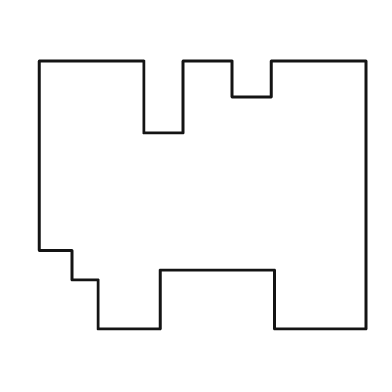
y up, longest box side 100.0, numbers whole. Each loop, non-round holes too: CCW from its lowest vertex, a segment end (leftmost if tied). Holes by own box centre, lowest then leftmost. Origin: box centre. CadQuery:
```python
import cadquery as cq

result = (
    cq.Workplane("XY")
    .moveTo(-32.0, -41.0)
    .lineTo(-13.0, -41.0)
    .lineTo(-13.0, -23.0)
    .lineTo(22.0, -23.0)
    .lineTo(22.0, -41.0)
    .lineTo(50.0, -41.0)
    .lineTo(50.0, 41.0)
    .lineTo(21.0, 41.0)
    .lineTo(21.0, 30.0)
    .lineTo(9.0, 30.0)
    .lineTo(9.0, 41.0)
    .lineTo(-6.0, 41.0)
    .lineTo(-6.0, 19.0)
    .lineTo(-18.0, 19.0)
    .lineTo(-18.0, 41.0)
    .lineTo(-50.0, 41.0)
    .lineTo(-50.0, -17.0)
    .lineTo(-40.0, -17.0)
    .lineTo(-40.0, -26.0)
    .lineTo(-32.0, -26.0)
    .close()
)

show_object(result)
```